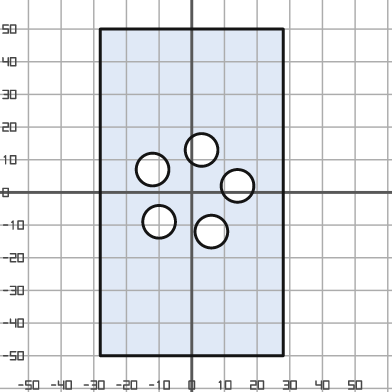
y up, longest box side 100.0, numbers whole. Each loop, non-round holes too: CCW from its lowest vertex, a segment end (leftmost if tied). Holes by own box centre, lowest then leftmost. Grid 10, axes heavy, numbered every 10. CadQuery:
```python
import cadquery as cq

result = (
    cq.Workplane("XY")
    .moveTo(-28.0, -50.0)
    .lineTo(28.0, -50.0)
    .lineTo(28.0, 50.0)
    .lineTo(-28.0, 50.0)
    .close()
    .moveTo(6.0, -12.0)
    .circle(5.0)
    .moveTo(-10.0, -9.0)
    .circle(5.0)
    .moveTo(14.0, 2.0)
    .circle(5.0)
    .moveTo(-12.0, 7.0)
    .circle(5.0)
    .moveTo(3.0, 13.0)
    .circle(5.0)
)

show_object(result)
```